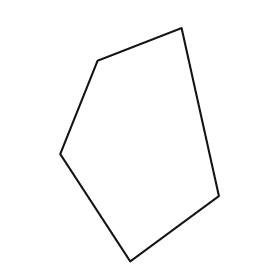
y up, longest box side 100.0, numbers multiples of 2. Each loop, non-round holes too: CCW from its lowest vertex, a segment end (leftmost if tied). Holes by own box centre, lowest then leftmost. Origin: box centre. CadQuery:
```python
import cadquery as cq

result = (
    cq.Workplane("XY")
    .moveTo(-4.0, -50.0)
    .lineTo(34.0, -22.0)
    .lineTo(18.0, 50.0)
    .lineTo(-18.0, 36.0)
    .lineTo(-34.0, -4.0)
    .close()
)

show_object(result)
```